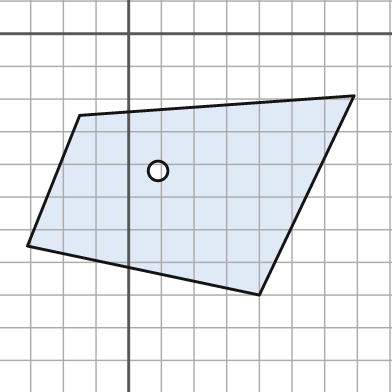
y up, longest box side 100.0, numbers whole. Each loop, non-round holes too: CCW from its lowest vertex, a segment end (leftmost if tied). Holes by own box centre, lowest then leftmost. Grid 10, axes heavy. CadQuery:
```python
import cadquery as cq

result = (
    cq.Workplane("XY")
    .moveTo(40.0, -80.0)
    .lineTo(69.0, -19.0)
    .lineTo(-15.0, -25.0)
    .lineTo(-31.0, -65.0)
    .close()
    .moveTo(9.0, -42.0)
    .circle(3.0)
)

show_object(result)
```